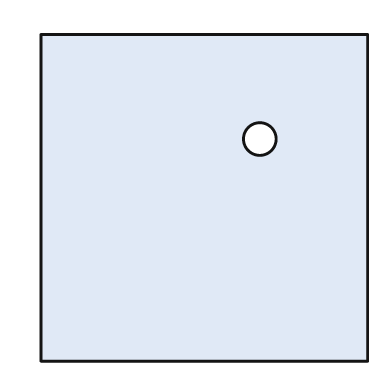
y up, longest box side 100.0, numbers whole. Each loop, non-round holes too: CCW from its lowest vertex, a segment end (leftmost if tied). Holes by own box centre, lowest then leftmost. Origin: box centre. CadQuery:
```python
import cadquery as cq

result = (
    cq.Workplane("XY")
    .moveTo(-50.0, -50.0)
    .lineTo(50.0, -50.0)
    .lineTo(50.0, 50.0)
    .lineTo(-50.0, 50.0)
    .close()
    .moveTo(17.0, 18.0)
    .circle(5.0)
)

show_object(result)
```